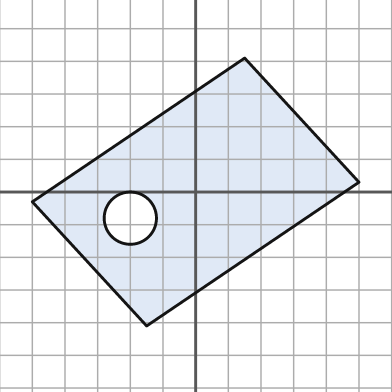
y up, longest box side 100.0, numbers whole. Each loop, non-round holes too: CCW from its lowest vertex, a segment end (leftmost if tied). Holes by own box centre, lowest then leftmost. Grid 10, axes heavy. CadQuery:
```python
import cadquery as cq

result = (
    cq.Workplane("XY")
    .moveTo(-15.0, -41.0)
    .lineTo(50.0, 3.0)
    .lineTo(15.0, 41.0)
    .lineTo(-50.0, -3.0)
    .close()
    .moveTo(-20.0, -8.0)
    .circle(8.0)
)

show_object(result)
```